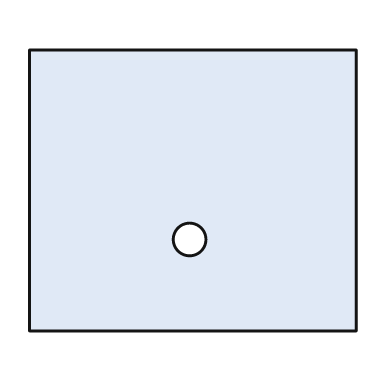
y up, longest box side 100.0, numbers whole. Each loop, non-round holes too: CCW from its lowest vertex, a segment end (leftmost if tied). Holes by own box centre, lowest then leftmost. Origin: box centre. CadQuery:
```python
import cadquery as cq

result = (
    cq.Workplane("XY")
    .moveTo(-50.0, -43.0)
    .lineTo(50.0, -43.0)
    .lineTo(50.0, 43.0)
    .lineTo(-50.0, 43.0)
    .close()
    .moveTo(-1.0, -15.0)
    .circle(5.0)
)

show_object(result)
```